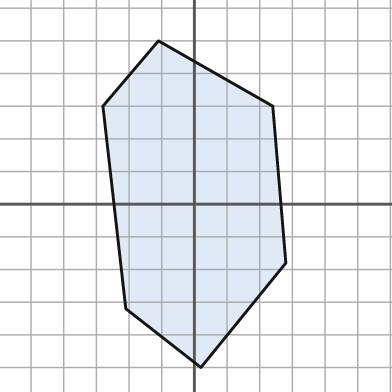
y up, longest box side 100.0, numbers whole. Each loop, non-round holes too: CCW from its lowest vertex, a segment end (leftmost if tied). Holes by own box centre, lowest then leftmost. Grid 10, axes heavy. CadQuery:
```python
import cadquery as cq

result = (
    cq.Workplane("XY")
    .moveTo(2.0, -50.0)
    .lineTo(28.0, -18.0)
    .lineTo(24.0, 30.0)
    .lineTo(-11.0, 50.0)
    .lineTo(-28.0, 30.0)
    .lineTo(-21.0, -32.0)
    .close()
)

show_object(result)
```